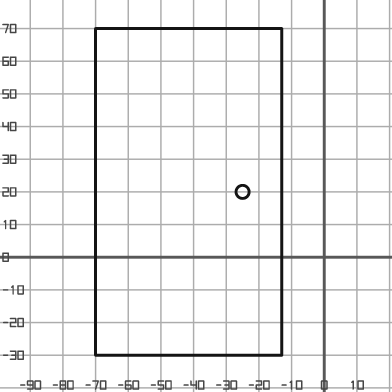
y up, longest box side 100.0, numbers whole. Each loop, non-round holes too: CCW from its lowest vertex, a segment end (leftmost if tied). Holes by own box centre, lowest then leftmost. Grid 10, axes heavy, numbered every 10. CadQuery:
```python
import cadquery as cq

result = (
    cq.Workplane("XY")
    .moveTo(-70.0, -30.0)
    .lineTo(-13.0, -30.0)
    .lineTo(-13.0, 70.0)
    .lineTo(-70.0, 70.0)
    .close()
    .moveTo(-25.0, 20.0)
    .circle(2.0)
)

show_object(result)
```